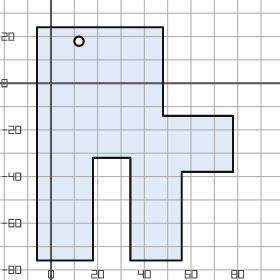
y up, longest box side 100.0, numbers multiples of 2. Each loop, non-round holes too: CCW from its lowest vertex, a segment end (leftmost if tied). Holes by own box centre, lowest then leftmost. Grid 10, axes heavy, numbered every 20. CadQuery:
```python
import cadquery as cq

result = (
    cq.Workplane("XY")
    .moveTo(-6.0, -76.0)
    .lineTo(18.0, -76.0)
    .lineTo(18.0, -32.0)
    .lineTo(34.0, -32.0)
    .lineTo(34.0, -76.0)
    .lineTo(56.0, -76.0)
    .lineTo(56.0, -38.0)
    .lineTo(78.0, -38.0)
    .lineTo(78.0, -14.0)
    .lineTo(48.0, -14.0)
    .lineTo(48.0, 24.0)
    .lineTo(-6.0, 24.0)
    .close()
    .moveTo(12.0, 18.0)
    .circle(2.0)
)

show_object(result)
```